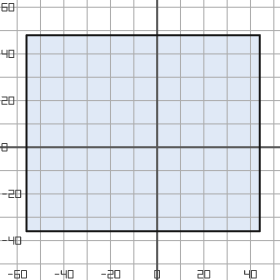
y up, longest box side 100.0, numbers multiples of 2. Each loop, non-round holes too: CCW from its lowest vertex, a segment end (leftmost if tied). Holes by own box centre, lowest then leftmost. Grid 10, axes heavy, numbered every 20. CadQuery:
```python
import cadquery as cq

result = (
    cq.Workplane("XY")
    .moveTo(-56.0, -36.0)
    .lineTo(44.0, -36.0)
    .lineTo(44.0, 48.0)
    .lineTo(-56.0, 48.0)
    .close()
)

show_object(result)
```